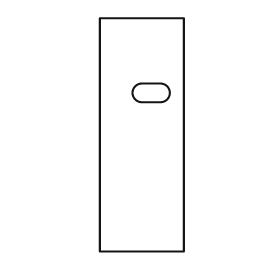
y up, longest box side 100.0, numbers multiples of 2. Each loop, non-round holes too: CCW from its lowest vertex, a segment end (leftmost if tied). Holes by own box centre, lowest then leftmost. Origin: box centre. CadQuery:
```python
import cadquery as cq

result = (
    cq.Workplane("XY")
    .moveTo(-18.0, -50.0)
    .lineTo(18.0, -50.0)
    .lineTo(18.0, 50.0)
    .lineTo(-18.0, 50.0)
    .close()
    .moveTo(0.0, 14.0)
    .lineTo(8.0, 14.0)
    .threePointArc((12.0, 18.0), (8.0, 22.0))
    .lineTo(0.0, 22.0)
    .threePointArc((-4.0, 18.0), (0.0, 14.0))
    .close()
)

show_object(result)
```